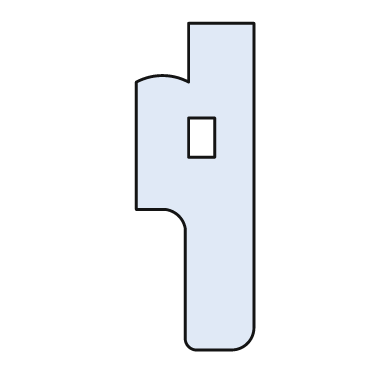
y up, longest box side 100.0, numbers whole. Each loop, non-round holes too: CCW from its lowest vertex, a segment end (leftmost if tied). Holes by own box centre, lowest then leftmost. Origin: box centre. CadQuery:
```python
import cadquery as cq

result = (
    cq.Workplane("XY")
    .moveTo(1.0, -50.0)
    .lineTo(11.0, -50.0)
    .threePointArc((16.0, -48.0), (18.0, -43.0))
    .lineTo(18.0, 50.0)
    .lineTo(-2.0, 50.0)
    .lineTo(-2.0, 32.0)
    .threePointArc((-10.0, 34.0), (-18.0, 32.0))
    .lineTo(-18.0, -7.0)
    .lineTo(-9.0, -7.0)
    .threePointArc((-5.0, -9.0), (-3.0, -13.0))
    .lineTo(-3.0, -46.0)
    .threePointArc((-2.0, -49.0), (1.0, -50.0))
    .close()
    .moveTo(-2.0, 9.0)
    .lineTo(6.0, 9.0)
    .lineTo(6.0, 21.0)
    .lineTo(-2.0, 21.0)
    .close()
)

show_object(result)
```